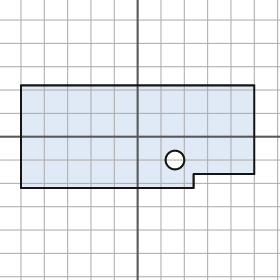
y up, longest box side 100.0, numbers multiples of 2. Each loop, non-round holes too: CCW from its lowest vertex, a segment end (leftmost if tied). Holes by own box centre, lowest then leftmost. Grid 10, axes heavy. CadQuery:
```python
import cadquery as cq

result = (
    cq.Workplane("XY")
    .moveTo(-50.0, -22.0)
    .lineTo(24.0, -22.0)
    .lineTo(24.0, -16.0)
    .lineTo(50.0, -16.0)
    .lineTo(50.0, 22.0)
    .lineTo(-50.0, 22.0)
    .close()
    .moveTo(16.0, -10.0)
    .circle(4.0)
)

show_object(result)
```